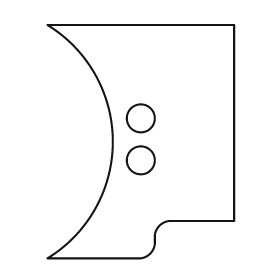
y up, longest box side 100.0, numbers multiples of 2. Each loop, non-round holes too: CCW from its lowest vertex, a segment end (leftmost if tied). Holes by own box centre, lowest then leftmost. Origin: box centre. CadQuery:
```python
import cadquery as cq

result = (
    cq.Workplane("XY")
    .moveTo(-40.0, -50.0)
    .lineTo(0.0, -50.0)
    .threePointArc((4.0, -48.0), (6.0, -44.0))
    .lineTo(6.0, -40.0)
    .threePointArc((8.0, -36.0), (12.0, -34.0))
    .lineTo(40.0, -34.0)
    .lineTo(40.0, 50.0)
    .lineTo(-40.0, 50.0)
    .threePointArc((-12.0, 0.0), (-40.0, -50.0))
    .close()
    .moveTo(0.0, -8.0)
    .circle(6.0)
    .moveTo(0.0, 10.0)
    .circle(6.0)
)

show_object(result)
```